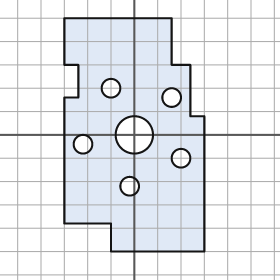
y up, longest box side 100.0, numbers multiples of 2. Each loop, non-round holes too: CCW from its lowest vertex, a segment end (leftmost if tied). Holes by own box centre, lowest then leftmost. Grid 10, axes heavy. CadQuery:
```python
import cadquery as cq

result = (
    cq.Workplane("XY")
    .moveTo(-10.0, -50.0)
    .lineTo(30.0, -50.0)
    .lineTo(30.0, 8.0)
    .lineTo(24.0, 8.0)
    .lineTo(24.0, 30.0)
    .lineTo(16.0, 30.0)
    .lineTo(16.0, 50.0)
    .lineTo(-30.0, 50.0)
    .lineTo(-30.0, 30.0)
    .lineTo(-24.0, 30.0)
    .lineTo(-24.0, 16.0)
    .lineTo(-30.0, 16.0)
    .lineTo(-30.0, -38.0)
    .lineTo(-10.0, -38.0)
    .close()
    .moveTo(-2.0, -22.0)
    .circle(4.0)
    .moveTo(20.0, -10.0)
    .circle(4.0)
    .moveTo(-22.0, -4.0)
    .circle(4.0)
    .moveTo(0.0, 0.0)
    .circle(8.0)
    .moveTo(16.0, 16.0)
    .circle(4.0)
    .moveTo(-10.0, 20.0)
    .circle(4.0)
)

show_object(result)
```